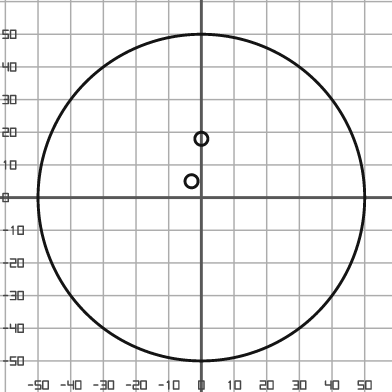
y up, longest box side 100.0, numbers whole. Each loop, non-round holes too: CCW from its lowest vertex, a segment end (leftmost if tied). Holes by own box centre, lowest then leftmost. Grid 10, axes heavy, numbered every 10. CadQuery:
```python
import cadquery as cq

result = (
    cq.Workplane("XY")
    .moveTo(0.0, 0.0)
    .circle(50.0)
    .moveTo(-3.0, 5.0)
    .circle(2.0)
    .moveTo(0.0, 18.0)
    .circle(2.0)
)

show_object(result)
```